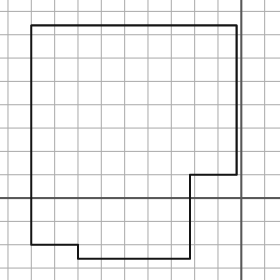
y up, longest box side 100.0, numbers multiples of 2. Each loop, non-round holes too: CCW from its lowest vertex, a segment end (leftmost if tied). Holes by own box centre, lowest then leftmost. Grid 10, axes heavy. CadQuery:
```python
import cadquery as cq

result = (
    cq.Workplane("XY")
    .moveTo(-70.0, -26.0)
    .lineTo(-22.0, -26.0)
    .lineTo(-22.0, 10.0)
    .lineTo(-2.0, 10.0)
    .lineTo(-2.0, 74.0)
    .lineTo(-90.0, 74.0)
    .lineTo(-90.0, -20.0)
    .lineTo(-70.0, -20.0)
    .close()
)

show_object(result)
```